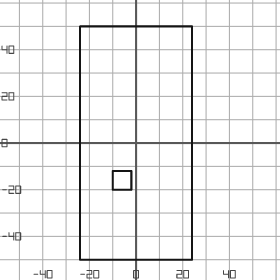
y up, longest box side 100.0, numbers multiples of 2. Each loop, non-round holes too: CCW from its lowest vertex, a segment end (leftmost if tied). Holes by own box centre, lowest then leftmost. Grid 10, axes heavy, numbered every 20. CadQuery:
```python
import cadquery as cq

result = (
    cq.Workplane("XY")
    .moveTo(-24.0, -50.0)
    .lineTo(24.0, -50.0)
    .lineTo(24.0, 50.0)
    .lineTo(-24.0, 50.0)
    .close()
    .moveTo(-10.0, -20.0)
    .lineTo(-2.0, -20.0)
    .lineTo(-2.0, -12.0)
    .lineTo(-10.0, -12.0)
    .close()
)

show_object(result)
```